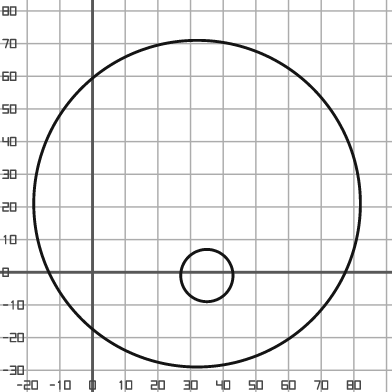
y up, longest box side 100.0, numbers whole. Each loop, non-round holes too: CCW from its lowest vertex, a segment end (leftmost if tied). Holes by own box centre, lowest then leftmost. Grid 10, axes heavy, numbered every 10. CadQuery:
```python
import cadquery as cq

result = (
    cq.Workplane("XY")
    .moveTo(32.0, 21.0)
    .circle(50.0)
    .moveTo(35.0, -1.0)
    .circle(8.0)
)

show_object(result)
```